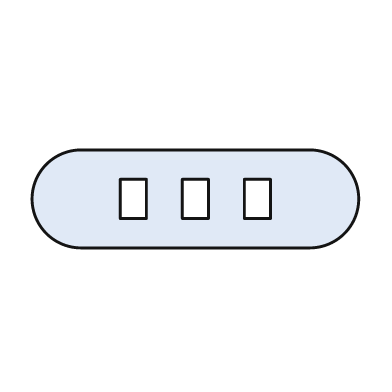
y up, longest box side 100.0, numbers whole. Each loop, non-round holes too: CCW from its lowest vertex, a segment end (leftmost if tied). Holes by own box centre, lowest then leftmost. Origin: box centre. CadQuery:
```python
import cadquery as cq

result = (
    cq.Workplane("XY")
    .moveTo(-35.0, -15.0)
    .lineTo(35.0, -15.0)
    .threePointArc((50.0, 0.0), (35.0, 15.0))
    .lineTo(-35.0, 15.0)
    .threePointArc((-50.0, 0.0), (-35.0, -15.0))
    .close()
    .moveTo(-23.0, -6.0)
    .lineTo(-15.0, -6.0)
    .lineTo(-15.0, 6.0)
    .lineTo(-23.0, 6.0)
    .close()
    .moveTo(-4.0, -6.0)
    .lineTo(4.0, -6.0)
    .lineTo(4.0, 6.0)
    .lineTo(-4.0, 6.0)
    .close()
    .moveTo(15.0, -6.0)
    .lineTo(23.0, -6.0)
    .lineTo(23.0, 6.0)
    .lineTo(15.0, 6.0)
    .close()
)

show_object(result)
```